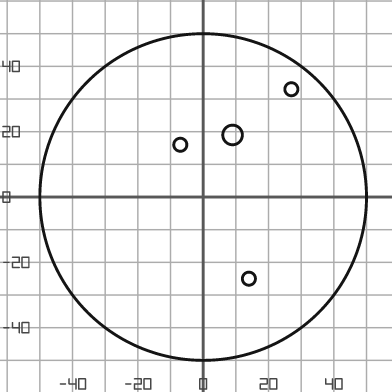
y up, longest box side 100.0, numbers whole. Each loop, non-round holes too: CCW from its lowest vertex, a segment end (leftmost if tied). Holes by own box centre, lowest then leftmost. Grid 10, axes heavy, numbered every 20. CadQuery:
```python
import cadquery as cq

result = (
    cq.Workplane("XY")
    .moveTo(0.0, 0.0)
    .circle(50.0)
    .moveTo(14.0, -25.0)
    .circle(2.0)
    .moveTo(-7.0, 16.0)
    .circle(2.0)
    .moveTo(9.0, 19.0)
    .circle(3.0)
    .moveTo(27.0, 33.0)
    .circle(2.0)
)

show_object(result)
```